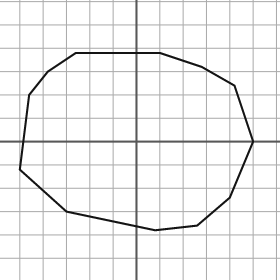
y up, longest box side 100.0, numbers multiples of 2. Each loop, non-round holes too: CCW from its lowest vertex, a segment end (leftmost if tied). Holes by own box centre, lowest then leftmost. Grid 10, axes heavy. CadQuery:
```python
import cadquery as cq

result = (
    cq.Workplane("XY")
    .moveTo(8.0, -38.0)
    .lineTo(26.0, -36.0)
    .lineTo(40.0, -24.0)
    .lineTo(50.0, 0.0)
    .lineTo(42.0, 24.0)
    .lineTo(28.0, 32.0)
    .lineTo(10.0, 38.0)
    .lineTo(-26.0, 38.0)
    .lineTo(-38.0, 30.0)
    .lineTo(-46.0, 20.0)
    .lineTo(-50.0, -12.0)
    .lineTo(-30.0, -30.0)
    .close()
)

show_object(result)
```